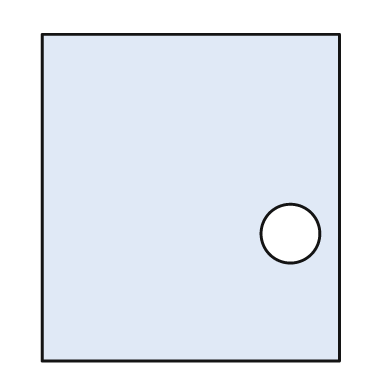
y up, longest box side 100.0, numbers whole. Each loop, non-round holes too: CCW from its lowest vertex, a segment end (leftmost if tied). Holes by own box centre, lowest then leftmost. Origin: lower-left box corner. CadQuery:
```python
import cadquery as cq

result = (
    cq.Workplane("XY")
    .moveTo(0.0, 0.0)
    .lineTo(91.0, 0.0)
    .lineTo(91.0, 100.0)
    .lineTo(0.0, 100.0)
    .close()
    .moveTo(76.0, 39.0)
    .circle(9.0)
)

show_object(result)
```